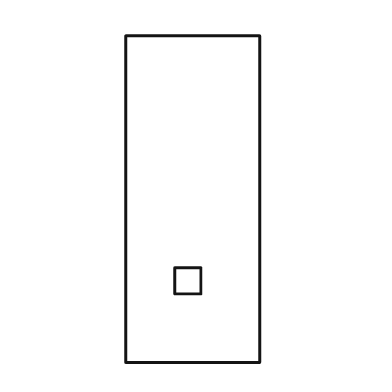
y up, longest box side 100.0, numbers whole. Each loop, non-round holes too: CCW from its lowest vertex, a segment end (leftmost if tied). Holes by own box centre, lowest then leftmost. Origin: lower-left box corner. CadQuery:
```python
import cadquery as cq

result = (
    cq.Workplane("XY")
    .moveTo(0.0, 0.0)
    .lineTo(41.0, 0.0)
    .lineTo(41.0, 100.0)
    .lineTo(0.0, 100.0)
    .close()
    .moveTo(15.0, 21.0)
    .lineTo(23.0, 21.0)
    .lineTo(23.0, 29.0)
    .lineTo(15.0, 29.0)
    .close()
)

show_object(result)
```